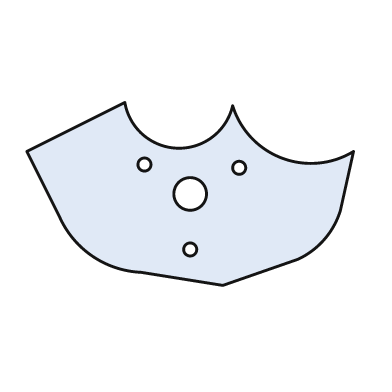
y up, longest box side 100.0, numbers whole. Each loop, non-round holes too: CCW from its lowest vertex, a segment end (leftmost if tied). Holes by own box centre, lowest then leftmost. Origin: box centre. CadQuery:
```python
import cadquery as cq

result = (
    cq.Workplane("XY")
    .moveTo(10.0, -28.0)
    .lineTo(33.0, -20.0)
    .threePointArc((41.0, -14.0), (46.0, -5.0))
    .lineTo(50.0, 13.0)
    .threePointArc((28.0, 11.0), (13.0, 27.0))
    .threePointArc((-4.0, 14.0), (-20.0, 28.0))
    .lineTo(-50.0, 13.0)
    .lineTo(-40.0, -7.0)
    .threePointArc((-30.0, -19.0), (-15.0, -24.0))
    .close()
    .moveTo(0.0, -17.0)
    .circle(2.0)
    .moveTo(0.0, 0.0)
    .circle(5.0)
    .moveTo(15.0, 8.0)
    .circle(2.0)
    .moveTo(-14.0, 9.0)
    .circle(2.0)
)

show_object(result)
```